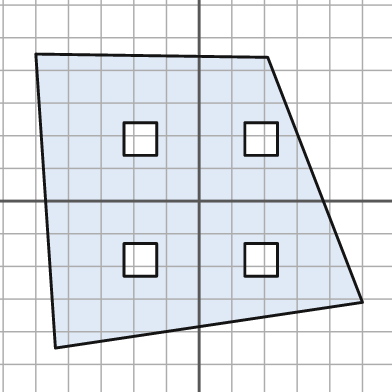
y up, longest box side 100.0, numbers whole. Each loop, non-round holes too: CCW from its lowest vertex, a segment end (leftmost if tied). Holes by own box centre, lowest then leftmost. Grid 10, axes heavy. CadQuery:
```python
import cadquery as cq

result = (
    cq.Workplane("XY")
    .moveTo(-44.0, -45.0)
    .lineTo(50.0, -31.0)
    .lineTo(21.0, 44.0)
    .lineTo(-50.0, 45.0)
    .close()
    .moveTo(-23.0, -23.0)
    .lineTo(-13.0, -23.0)
    .lineTo(-13.0, -13.0)
    .lineTo(-23.0, -13.0)
    .close()
    .moveTo(14.0, -23.0)
    .lineTo(24.0, -23.0)
    .lineTo(24.0, -13.0)
    .lineTo(14.0, -13.0)
    .close()
    .moveTo(-23.0, 14.0)
    .lineTo(-13.0, 14.0)
    .lineTo(-13.0, 24.0)
    .lineTo(-23.0, 24.0)
    .close()
    .moveTo(14.0, 14.0)
    .lineTo(24.0, 14.0)
    .lineTo(24.0, 24.0)
    .lineTo(14.0, 24.0)
    .close()
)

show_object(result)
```